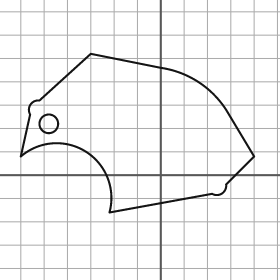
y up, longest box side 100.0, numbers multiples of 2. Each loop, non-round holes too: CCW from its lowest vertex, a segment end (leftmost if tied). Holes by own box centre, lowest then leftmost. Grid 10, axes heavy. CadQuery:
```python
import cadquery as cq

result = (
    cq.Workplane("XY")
    .moveTo(-22.0, -16.0)
    .lineTo(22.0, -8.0)
    .threePointArc((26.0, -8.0), (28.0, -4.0))
    .lineTo(40.0, 8.0)
    .lineTo(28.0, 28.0)
    .threePointArc((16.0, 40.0), (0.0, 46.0))
    .lineTo(-30.0, 52.0)
    .lineTo(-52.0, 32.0)
    .threePointArc((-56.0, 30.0), (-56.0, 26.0))
    .lineTo(-60.0, 8.0)
    .threePointArc((-32.0, 10.0), (-22.0, -16.0))
    .close()
    .moveTo(-48.0, 22.0)
    .circle(4.0)
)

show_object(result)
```